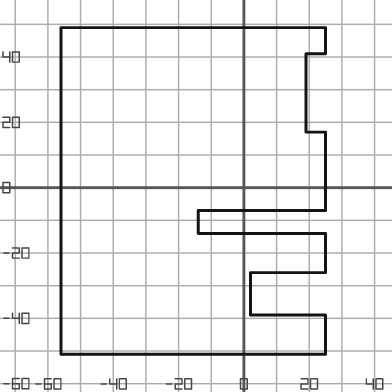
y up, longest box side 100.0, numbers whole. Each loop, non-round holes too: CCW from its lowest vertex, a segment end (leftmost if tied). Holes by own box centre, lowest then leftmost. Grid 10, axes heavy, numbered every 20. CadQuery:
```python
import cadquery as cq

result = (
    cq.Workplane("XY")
    .moveTo(-56.0, -51.0)
    .lineTo(25.0, -51.0)
    .lineTo(25.0, -39.0)
    .lineTo(2.0, -39.0)
    .lineTo(2.0, -26.0)
    .lineTo(25.0, -26.0)
    .lineTo(25.0, -14.0)
    .lineTo(-14.0, -14.0)
    .lineTo(-14.0, -7.0)
    .lineTo(25.0, -7.0)
    .lineTo(25.0, 17.0)
    .lineTo(19.0, 17.0)
    .lineTo(19.0, 41.0)
    .lineTo(25.0, 41.0)
    .lineTo(25.0, 49.0)
    .lineTo(-56.0, 49.0)
    .close()
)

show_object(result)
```